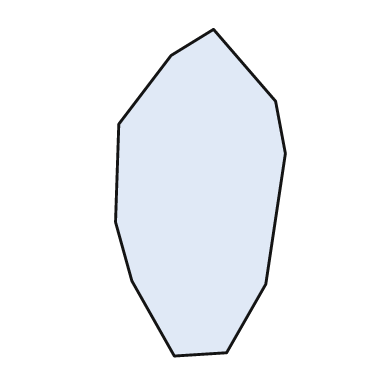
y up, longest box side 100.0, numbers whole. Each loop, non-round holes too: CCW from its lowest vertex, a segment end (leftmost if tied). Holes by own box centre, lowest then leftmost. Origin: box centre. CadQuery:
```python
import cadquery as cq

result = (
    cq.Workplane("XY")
    .moveTo(-8.0, -50.0)
    .lineTo(8.0, -49.0)
    .lineTo(20.0, -28.0)
    .lineTo(26.0, 12.0)
    .lineTo(23.0, 28.0)
    .lineTo(4.0, 50.0)
    .lineTo(-9.0, 42.0)
    .lineTo(-25.0, 21.0)
    .lineTo(-26.0, -9.0)
    .lineTo(-21.0, -27.0)
    .close()
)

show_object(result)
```